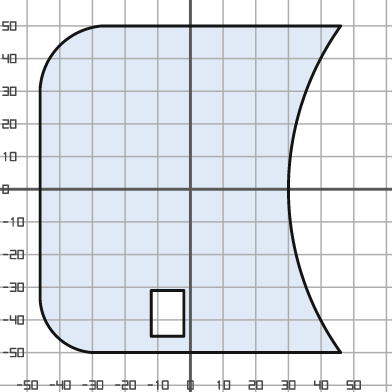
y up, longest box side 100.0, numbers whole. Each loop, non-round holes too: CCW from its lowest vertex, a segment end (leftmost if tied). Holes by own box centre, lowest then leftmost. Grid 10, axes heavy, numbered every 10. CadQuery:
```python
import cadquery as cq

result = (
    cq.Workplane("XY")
    .moveTo(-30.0, -50.0)
    .lineTo(46.0, -50.0)
    .threePointArc((30.0, 0.0), (46.0, 50.0))
    .lineTo(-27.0, 50.0)
    .threePointArc((-40.0, 44.0), (-46.0, 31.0))
    .lineTo(-46.0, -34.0)
    .threePointArc((-41.0, -45.0), (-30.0, -50.0))
    .close()
    .moveTo(-12.0, -45.0)
    .lineTo(-2.0, -45.0)
    .lineTo(-2.0, -31.0)
    .lineTo(-12.0, -31.0)
    .close()
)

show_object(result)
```